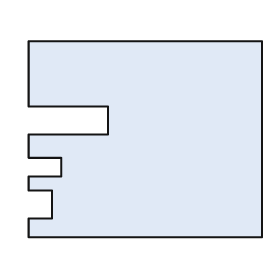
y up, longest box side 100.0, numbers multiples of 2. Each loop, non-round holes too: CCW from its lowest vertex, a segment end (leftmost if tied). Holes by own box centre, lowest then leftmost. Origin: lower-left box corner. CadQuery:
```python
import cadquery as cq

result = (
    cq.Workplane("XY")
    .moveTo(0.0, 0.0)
    .lineTo(100.0, 0.0)
    .lineTo(100.0, 84.0)
    .lineTo(0.0, 84.0)
    .lineTo(0.0, 56.0)
    .lineTo(34.0, 56.0)
    .lineTo(34.0, 44.0)
    .lineTo(0.0, 44.0)
    .lineTo(0.0, 34.0)
    .lineTo(14.0, 34.0)
    .lineTo(14.0, 26.0)
    .lineTo(0.0, 26.0)
    .lineTo(0.0, 20.0)
    .lineTo(10.0, 20.0)
    .lineTo(10.0, 8.0)
    .lineTo(0.0, 8.0)
    .close()
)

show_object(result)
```